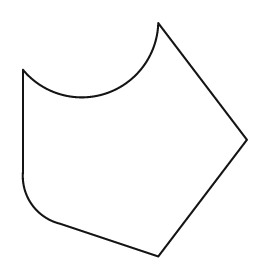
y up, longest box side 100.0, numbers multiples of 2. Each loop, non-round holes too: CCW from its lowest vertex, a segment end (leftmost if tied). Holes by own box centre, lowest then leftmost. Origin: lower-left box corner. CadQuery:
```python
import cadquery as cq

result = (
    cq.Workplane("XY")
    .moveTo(58.0, 0.0)
    .lineTo(96.0, 50.0)
    .lineTo(58.0, 100.0)
    .threePointArc((36.0, 70.0), (0.0, 80.0))
    .lineTo(0.0, 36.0)
    .threePointArc((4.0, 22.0), (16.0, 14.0))
    .close()
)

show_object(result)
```